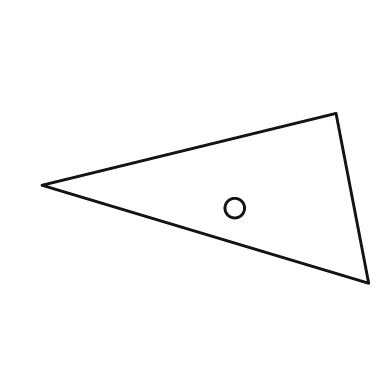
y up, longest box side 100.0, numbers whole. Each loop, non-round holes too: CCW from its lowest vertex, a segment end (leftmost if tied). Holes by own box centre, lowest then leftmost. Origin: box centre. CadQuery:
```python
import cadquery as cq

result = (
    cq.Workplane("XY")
    .moveTo(50.0, -26.0)
    .lineTo(40.0, 26.0)
    .lineTo(-50.0, 4.0)
    .close()
    .moveTo(9.0, -3.0)
    .circle(3.0)
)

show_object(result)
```